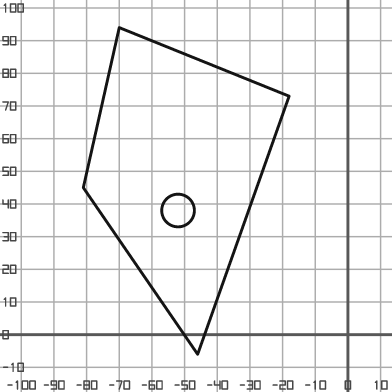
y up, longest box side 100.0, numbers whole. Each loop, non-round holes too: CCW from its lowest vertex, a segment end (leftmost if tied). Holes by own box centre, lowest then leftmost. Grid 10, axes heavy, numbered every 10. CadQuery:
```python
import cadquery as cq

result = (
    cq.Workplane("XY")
    .moveTo(-46.0, -6.0)
    .lineTo(-18.0, 73.0)
    .lineTo(-70.0, 94.0)
    .lineTo(-81.0, 45.0)
    .close()
    .moveTo(-52.0, 38.0)
    .circle(5.0)
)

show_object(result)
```